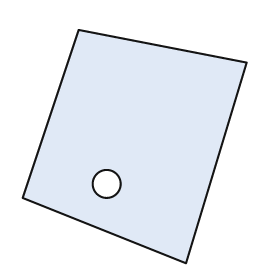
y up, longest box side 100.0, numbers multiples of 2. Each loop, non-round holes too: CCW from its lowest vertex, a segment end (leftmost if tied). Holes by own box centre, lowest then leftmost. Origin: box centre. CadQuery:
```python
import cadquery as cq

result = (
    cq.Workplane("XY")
    .moveTo(22.0, -50.0)
    .lineTo(48.0, 36.0)
    .lineTo(-24.0, 50.0)
    .lineTo(-48.0, -22.0)
    .close()
    .moveTo(-12.0, -16.0)
    .circle(6.0)
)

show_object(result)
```